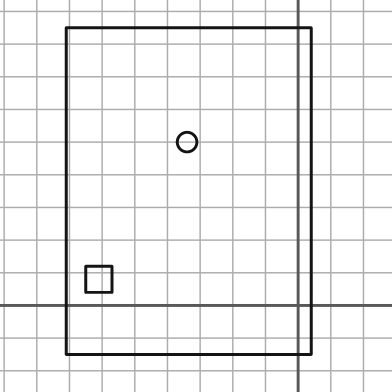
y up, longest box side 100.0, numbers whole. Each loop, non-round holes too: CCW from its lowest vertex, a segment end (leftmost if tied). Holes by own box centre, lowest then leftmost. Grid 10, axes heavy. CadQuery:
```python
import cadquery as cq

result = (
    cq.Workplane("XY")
    .moveTo(-71.0, -15.0)
    .lineTo(4.0, -15.0)
    .lineTo(4.0, 85.0)
    .lineTo(-71.0, 85.0)
    .close()
    .moveTo(-65.0, 4.0)
    .lineTo(-57.0, 4.0)
    .lineTo(-57.0, 12.0)
    .lineTo(-65.0, 12.0)
    .close()
    .moveTo(-34.0, 50.0)
    .circle(3.0)
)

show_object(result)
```